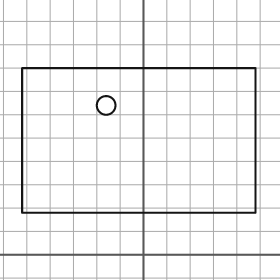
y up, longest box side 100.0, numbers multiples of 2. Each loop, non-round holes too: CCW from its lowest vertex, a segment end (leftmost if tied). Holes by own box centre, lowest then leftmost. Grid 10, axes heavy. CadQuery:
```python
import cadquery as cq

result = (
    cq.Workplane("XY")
    .moveTo(-52.0, 18.0)
    .lineTo(48.0, 18.0)
    .lineTo(48.0, 80.0)
    .lineTo(-52.0, 80.0)
    .close()
    .moveTo(-16.0, 64.0)
    .circle(4.0)
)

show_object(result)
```